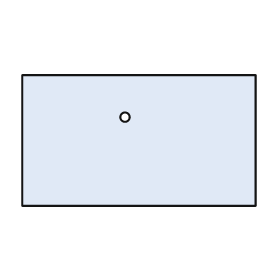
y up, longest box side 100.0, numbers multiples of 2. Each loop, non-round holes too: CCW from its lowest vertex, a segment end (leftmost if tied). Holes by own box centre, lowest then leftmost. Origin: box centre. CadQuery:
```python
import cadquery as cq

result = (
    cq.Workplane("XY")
    .moveTo(-50.0, -28.0)
    .lineTo(50.0, -28.0)
    .lineTo(50.0, 28.0)
    .lineTo(-50.0, 28.0)
    .close()
    .moveTo(-6.0, 10.0)
    .circle(2.0)
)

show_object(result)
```